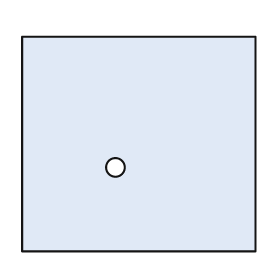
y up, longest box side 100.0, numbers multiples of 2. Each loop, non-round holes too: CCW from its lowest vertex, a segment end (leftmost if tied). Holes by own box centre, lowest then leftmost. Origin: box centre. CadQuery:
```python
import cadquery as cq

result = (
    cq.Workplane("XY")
    .moveTo(-50.0, -46.0)
    .lineTo(50.0, -46.0)
    .lineTo(50.0, 46.0)
    .lineTo(-50.0, 46.0)
    .close()
    .moveTo(-10.0, -10.0)
    .circle(4.0)
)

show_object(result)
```